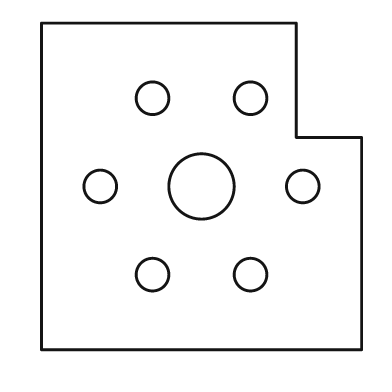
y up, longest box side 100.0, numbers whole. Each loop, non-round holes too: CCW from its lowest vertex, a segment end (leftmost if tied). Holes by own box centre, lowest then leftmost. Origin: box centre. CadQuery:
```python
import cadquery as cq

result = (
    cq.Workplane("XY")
    .moveTo(-49.0, -50.0)
    .lineTo(49.0, -50.0)
    .lineTo(49.0, 15.0)
    .lineTo(29.0, 15.0)
    .lineTo(29.0, 50.0)
    .lineTo(-49.0, 50.0)
    .close()
    .moveTo(-15.0, -27.0)
    .circle(5.0)
    .moveTo(15.0, -27.0)
    .circle(5.0)
    .moveTo(-31.0, 0.0)
    .circle(5.0)
    .moveTo(0.0, 0.0)
    .circle(10.0)
    .moveTo(31.0, 0.0)
    .circle(5.0)
    .moveTo(-15.0, 27.0)
    .circle(5.0)
    .moveTo(15.0, 27.0)
    .circle(5.0)
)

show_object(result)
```